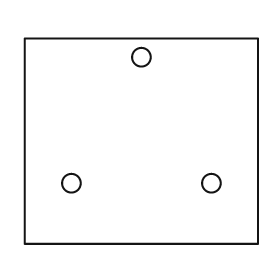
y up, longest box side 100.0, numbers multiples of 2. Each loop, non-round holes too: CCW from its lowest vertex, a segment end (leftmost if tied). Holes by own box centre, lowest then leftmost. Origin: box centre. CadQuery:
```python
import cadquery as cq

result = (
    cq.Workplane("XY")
    .moveTo(-50.0, -44.0)
    .lineTo(50.0, -44.0)
    .lineTo(50.0, 44.0)
    .lineTo(-50.0, 44.0)
    .close()
    .moveTo(-30.0, -18.0)
    .circle(4.0)
    .moveTo(30.0, -18.0)
    .circle(4.0)
    .moveTo(0.0, 36.0)
    .circle(4.0)
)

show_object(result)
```